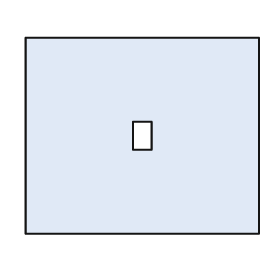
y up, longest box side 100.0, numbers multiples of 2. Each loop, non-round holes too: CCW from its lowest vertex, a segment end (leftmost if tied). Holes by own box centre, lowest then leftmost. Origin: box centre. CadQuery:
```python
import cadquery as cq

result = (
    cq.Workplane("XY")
    .moveTo(-50.0, -42.0)
    .lineTo(50.0, -42.0)
    .lineTo(50.0, 42.0)
    .lineTo(-50.0, 42.0)
    .close()
    .moveTo(-4.0, -6.0)
    .lineTo(4.0, -6.0)
    .lineTo(4.0, 6.0)
    .lineTo(-4.0, 6.0)
    .close()
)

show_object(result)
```